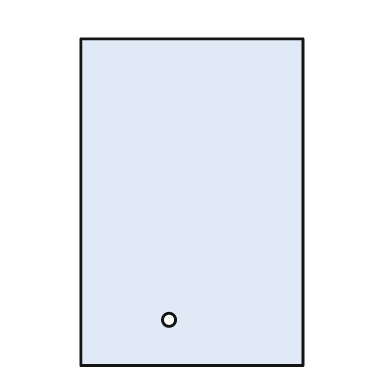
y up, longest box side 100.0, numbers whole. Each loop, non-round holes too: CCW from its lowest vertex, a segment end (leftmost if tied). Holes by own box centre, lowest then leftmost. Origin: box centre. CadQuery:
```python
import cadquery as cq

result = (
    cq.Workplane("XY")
    .moveTo(-34.0, -50.0)
    .lineTo(34.0, -50.0)
    .lineTo(34.0, 50.0)
    .lineTo(-34.0, 50.0)
    .close()
    .moveTo(-7.0, -36.0)
    .circle(2.0)
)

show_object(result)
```